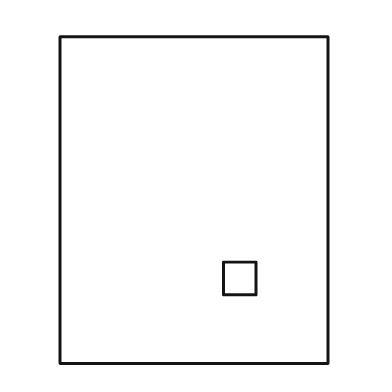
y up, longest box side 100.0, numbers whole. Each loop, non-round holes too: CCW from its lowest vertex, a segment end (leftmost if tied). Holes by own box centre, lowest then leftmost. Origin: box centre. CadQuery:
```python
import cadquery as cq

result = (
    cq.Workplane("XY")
    .moveTo(-41.0, -50.0)
    .lineTo(41.0, -50.0)
    .lineTo(41.0, 50.0)
    .lineTo(-41.0, 50.0)
    .close()
    .moveTo(9.0, -29.0)
    .lineTo(19.0, -29.0)
    .lineTo(19.0, -19.0)
    .lineTo(9.0, -19.0)
    .close()
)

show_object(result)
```